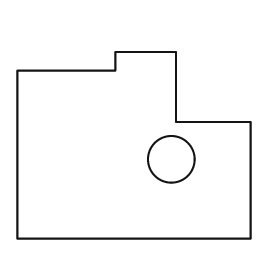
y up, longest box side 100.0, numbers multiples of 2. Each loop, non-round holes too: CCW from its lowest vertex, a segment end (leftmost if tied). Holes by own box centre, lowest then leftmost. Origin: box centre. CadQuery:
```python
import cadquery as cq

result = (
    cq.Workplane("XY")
    .moveTo(-50.0, -40.0)
    .lineTo(50.0, -40.0)
    .lineTo(50.0, 10.0)
    .lineTo(18.0, 10.0)
    .lineTo(18.0, 40.0)
    .lineTo(-8.0, 40.0)
    .lineTo(-8.0, 32.0)
    .lineTo(-50.0, 32.0)
    .close()
    .moveTo(16.0, -6.0)
    .circle(10.0)
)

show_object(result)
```